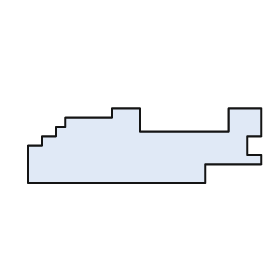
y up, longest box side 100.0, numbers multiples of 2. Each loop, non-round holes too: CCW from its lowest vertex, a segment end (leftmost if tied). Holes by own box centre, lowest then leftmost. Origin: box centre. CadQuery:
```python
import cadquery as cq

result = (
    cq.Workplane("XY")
    .moveTo(-50.0, -16.0)
    .lineTo(26.0, -16.0)
    .lineTo(26.0, -8.0)
    .lineTo(50.0, -8.0)
    .lineTo(50.0, -4.0)
    .lineTo(44.0, -4.0)
    .lineTo(44.0, 4.0)
    .lineTo(50.0, 4.0)
    .lineTo(50.0, 16.0)
    .lineTo(36.0, 16.0)
    .lineTo(36.0, 6.0)
    .lineTo(-2.0, 6.0)
    .lineTo(-2.0, 16.0)
    .lineTo(-14.0, 16.0)
    .lineTo(-14.0, 12.0)
    .lineTo(-34.0, 12.0)
    .lineTo(-34.0, 8.0)
    .lineTo(-38.0, 8.0)
    .lineTo(-38.0, 4.0)
    .lineTo(-44.0, 4.0)
    .lineTo(-44.0, 0.0)
    .lineTo(-50.0, 0.0)
    .close()
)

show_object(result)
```